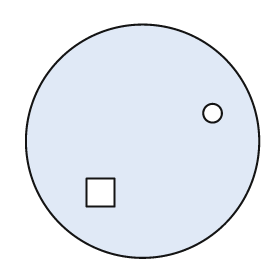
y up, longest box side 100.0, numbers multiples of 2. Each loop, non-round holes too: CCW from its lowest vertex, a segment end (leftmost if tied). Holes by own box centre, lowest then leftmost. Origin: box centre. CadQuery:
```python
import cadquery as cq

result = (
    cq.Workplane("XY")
    .moveTo(0.0, 0.0)
    .circle(50.0)
    .moveTo(-24.0, -28.0)
    .lineTo(-12.0, -28.0)
    .lineTo(-12.0, -16.0)
    .lineTo(-24.0, -16.0)
    .close()
    .moveTo(30.0, 12.0)
    .circle(4.0)
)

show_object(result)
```